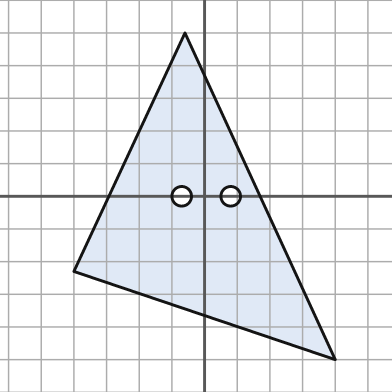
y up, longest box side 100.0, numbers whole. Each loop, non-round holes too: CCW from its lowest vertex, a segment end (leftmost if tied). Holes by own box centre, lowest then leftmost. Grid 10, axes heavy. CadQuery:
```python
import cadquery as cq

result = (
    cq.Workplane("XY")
    .moveTo(40.0, -50.0)
    .lineTo(-6.0, 50.0)
    .lineTo(-40.0, -23.0)
    .close()
    .moveTo(-7.0, 0.0)
    .circle(3.0)
    .moveTo(8.0, 0.0)
    .circle(3.0)
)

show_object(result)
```